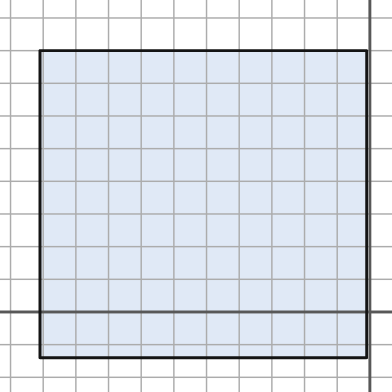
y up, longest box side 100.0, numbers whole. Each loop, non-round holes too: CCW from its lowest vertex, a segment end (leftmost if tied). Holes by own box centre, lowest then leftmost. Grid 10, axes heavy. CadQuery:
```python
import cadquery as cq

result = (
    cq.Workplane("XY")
    .moveTo(-101.0, -14.0)
    .lineTo(-1.0, -14.0)
    .lineTo(-1.0, 80.0)
    .lineTo(-101.0, 80.0)
    .close()
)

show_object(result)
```